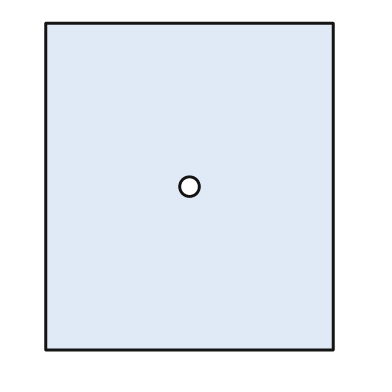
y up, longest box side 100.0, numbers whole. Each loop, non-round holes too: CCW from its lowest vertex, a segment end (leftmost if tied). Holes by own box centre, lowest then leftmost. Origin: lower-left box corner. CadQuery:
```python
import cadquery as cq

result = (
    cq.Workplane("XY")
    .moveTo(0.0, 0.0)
    .lineTo(88.0, 0.0)
    .lineTo(88.0, 100.0)
    .lineTo(0.0, 100.0)
    .close()
    .moveTo(44.0, 50.0)
    .circle(3.0)
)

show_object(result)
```